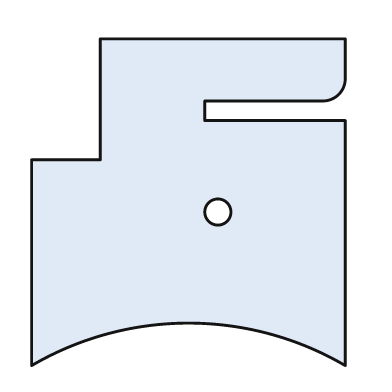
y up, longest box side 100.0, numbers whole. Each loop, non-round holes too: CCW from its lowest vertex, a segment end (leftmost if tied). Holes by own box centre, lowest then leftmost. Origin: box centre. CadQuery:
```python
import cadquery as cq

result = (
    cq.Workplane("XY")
    .moveTo(-48.0, -50.0)
    .threePointArc((0.0, -37.0), (48.0, -50.0))
    .lineTo(48.0, 25.0)
    .lineTo(5.0, 25.0)
    .lineTo(5.0, 31.0)
    .lineTo(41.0, 31.0)
    .threePointArc((46.0, 33.0), (48.0, 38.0))
    .lineTo(48.0, 50.0)
    .lineTo(-27.0, 50.0)
    .lineTo(-27.0, 13.0)
    .lineTo(-48.0, 13.0)
    .close()
    .moveTo(9.0, -3.0)
    .circle(4.0)
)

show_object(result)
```